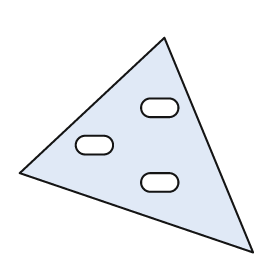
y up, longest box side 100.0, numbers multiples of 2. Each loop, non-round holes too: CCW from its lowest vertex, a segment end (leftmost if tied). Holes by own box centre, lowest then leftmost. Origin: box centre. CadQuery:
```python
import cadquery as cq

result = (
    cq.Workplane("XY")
    .moveTo(50.0, -46.0)
    .lineTo(12.0, 46.0)
    .lineTo(-50.0, -12.0)
    .close()
    .moveTo(6.0, -20.0)
    .lineTo(14.0, -20.0)
    .threePointArc((18.0, -16.0), (14.0, -12.0))
    .lineTo(6.0, -12.0)
    .threePointArc((2.0, -16.0), (6.0, -20.0))
    .close()
    .moveTo(-22.0, -4.0)
    .lineTo(-14.0, -4.0)
    .threePointArc((-10.0, 0.0), (-14.0, 4.0))
    .lineTo(-22.0, 4.0)
    .threePointArc((-26.0, 0.0), (-22.0, -4.0))
    .close()
    .moveTo(6.0, 12.0)
    .lineTo(14.0, 12.0)
    .threePointArc((18.0, 16.0), (14.0, 20.0))
    .lineTo(6.0, 20.0)
    .threePointArc((2.0, 16.0), (6.0, 12.0))
    .close()
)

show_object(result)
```